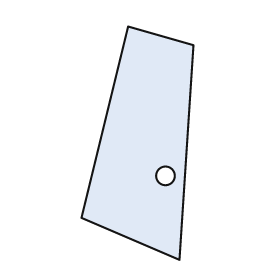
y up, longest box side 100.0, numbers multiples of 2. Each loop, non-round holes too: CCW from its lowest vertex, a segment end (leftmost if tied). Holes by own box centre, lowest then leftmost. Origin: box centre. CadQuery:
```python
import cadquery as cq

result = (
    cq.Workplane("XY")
    .moveTo(18.0, -50.0)
    .lineTo(24.0, 42.0)
    .lineTo(-4.0, 50.0)
    .lineTo(-24.0, -32.0)
    .close()
    .moveTo(12.0, -14.0)
    .circle(4.0)
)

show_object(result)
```